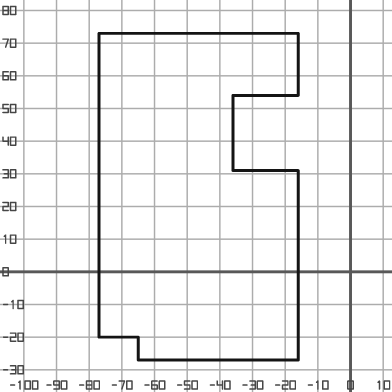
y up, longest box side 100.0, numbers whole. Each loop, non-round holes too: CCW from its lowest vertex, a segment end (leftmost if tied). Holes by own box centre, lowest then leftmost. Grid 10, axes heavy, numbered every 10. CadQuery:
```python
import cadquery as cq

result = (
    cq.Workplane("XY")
    .moveTo(-65.0, -27.0)
    .lineTo(-16.0, -27.0)
    .lineTo(-16.0, 31.0)
    .lineTo(-36.0, 31.0)
    .lineTo(-36.0, 54.0)
    .lineTo(-16.0, 54.0)
    .lineTo(-16.0, 73.0)
    .lineTo(-77.0, 73.0)
    .lineTo(-77.0, -20.0)
    .lineTo(-65.0, -20.0)
    .close()
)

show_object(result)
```